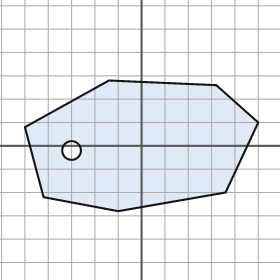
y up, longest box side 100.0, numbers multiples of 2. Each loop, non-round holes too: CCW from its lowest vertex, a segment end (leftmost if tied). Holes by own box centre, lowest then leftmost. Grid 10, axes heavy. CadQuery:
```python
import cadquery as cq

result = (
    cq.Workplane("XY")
    .moveTo(-10.0, -28.0)
    .lineTo(36.0, -20.0)
    .lineTo(50.0, 10.0)
    .lineTo(32.0, 26.0)
    .lineTo(-14.0, 28.0)
    .lineTo(-50.0, 8.0)
    .lineTo(-42.0, -22.0)
    .close()
    .moveTo(-30.0, -2.0)
    .circle(4.0)
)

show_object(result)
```